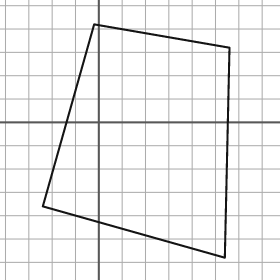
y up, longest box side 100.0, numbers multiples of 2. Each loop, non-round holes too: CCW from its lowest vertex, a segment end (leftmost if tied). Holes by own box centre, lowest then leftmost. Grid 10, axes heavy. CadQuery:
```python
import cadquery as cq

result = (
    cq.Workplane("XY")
    .moveTo(54.0, -58.0)
    .lineTo(56.0, 32.0)
    .lineTo(-2.0, 42.0)
    .lineTo(-24.0, -36.0)
    .close()
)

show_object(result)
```